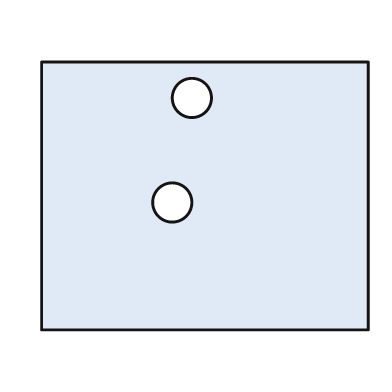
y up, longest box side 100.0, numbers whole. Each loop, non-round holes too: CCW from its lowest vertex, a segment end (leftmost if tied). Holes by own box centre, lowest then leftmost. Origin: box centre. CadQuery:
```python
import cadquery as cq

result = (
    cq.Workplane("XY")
    .moveTo(-50.0, -41.0)
    .lineTo(50.0, -41.0)
    .lineTo(50.0, 41.0)
    .lineTo(-50.0, 41.0)
    .close()
    .moveTo(-10.0, -2.0)
    .circle(6.0)
    .moveTo(-4.0, 30.0)
    .circle(6.0)
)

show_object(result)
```